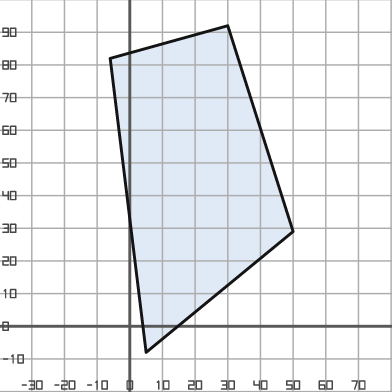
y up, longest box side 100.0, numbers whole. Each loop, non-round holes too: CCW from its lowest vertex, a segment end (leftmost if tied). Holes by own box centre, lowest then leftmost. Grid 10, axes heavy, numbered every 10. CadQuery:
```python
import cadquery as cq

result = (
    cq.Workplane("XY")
    .moveTo(5.0, -8.0)
    .lineTo(50.0, 29.0)
    .lineTo(30.0, 92.0)
    .lineTo(-6.0, 82.0)
    .close()
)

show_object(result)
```